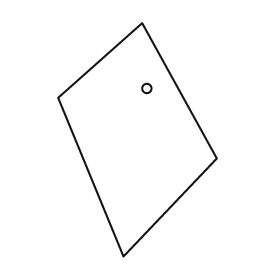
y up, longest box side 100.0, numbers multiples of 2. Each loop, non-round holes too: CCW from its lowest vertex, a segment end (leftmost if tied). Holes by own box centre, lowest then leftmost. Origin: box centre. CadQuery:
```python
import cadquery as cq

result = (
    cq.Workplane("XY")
    .moveTo(-6.0, -50.0)
    .lineTo(34.0, -8.0)
    .lineTo(2.0, 50.0)
    .lineTo(-34.0, 18.0)
    .close()
    .moveTo(4.0, 22.0)
    .circle(2.0)
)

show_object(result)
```